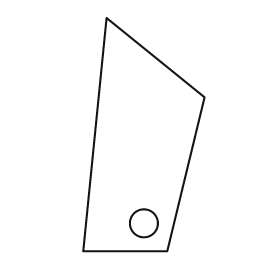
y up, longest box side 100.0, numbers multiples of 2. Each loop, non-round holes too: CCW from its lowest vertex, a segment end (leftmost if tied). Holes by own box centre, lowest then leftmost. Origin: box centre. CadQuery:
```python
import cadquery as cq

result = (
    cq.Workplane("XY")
    .moveTo(-26.0, -50.0)
    .lineTo(10.0, -50.0)
    .lineTo(26.0, 16.0)
    .lineTo(-16.0, 50.0)
    .close()
    .moveTo(0.0, -38.0)
    .circle(6.0)
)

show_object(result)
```